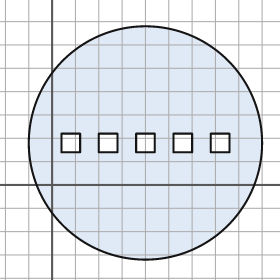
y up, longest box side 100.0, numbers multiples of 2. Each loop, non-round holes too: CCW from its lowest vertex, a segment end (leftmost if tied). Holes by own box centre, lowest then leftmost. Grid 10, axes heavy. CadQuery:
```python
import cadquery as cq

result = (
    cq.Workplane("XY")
    .moveTo(40.0, 18.0)
    .circle(50.0)
    .moveTo(4.0, 14.0)
    .lineTo(12.0, 14.0)
    .lineTo(12.0, 22.0)
    .lineTo(4.0, 22.0)
    .close()
    .moveTo(20.0, 14.0)
    .lineTo(28.0, 14.0)
    .lineTo(28.0, 22.0)
    .lineTo(20.0, 22.0)
    .close()
    .moveTo(36.0, 14.0)
    .lineTo(44.0, 14.0)
    .lineTo(44.0, 22.0)
    .lineTo(36.0, 22.0)
    .close()
    .moveTo(52.0, 14.0)
    .lineTo(60.0, 14.0)
    .lineTo(60.0, 22.0)
    .lineTo(52.0, 22.0)
    .close()
    .moveTo(68.0, 14.0)
    .lineTo(76.0, 14.0)
    .lineTo(76.0, 22.0)
    .lineTo(68.0, 22.0)
    .close()
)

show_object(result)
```